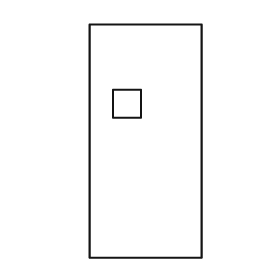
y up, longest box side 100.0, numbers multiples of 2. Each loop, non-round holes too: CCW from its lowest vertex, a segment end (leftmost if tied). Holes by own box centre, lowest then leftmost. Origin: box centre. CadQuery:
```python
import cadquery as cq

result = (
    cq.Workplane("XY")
    .moveTo(-24.0, -50.0)
    .lineTo(24.0, -50.0)
    .lineTo(24.0, 50.0)
    .lineTo(-24.0, 50.0)
    .close()
    .moveTo(-14.0, 10.0)
    .lineTo(-2.0, 10.0)
    .lineTo(-2.0, 22.0)
    .lineTo(-14.0, 22.0)
    .close()
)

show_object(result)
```